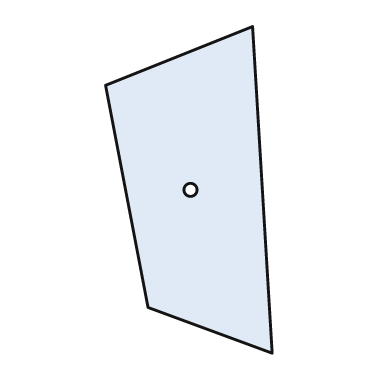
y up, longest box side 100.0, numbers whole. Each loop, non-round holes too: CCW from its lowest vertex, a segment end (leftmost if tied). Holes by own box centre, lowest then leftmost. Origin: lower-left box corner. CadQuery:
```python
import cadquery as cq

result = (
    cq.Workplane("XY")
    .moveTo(51.0, 0.0)
    .lineTo(45.0, 100.0)
    .lineTo(0.0, 82.0)
    .lineTo(13.0, 14.0)
    .close()
    .moveTo(26.0, 50.0)
    .circle(2.0)
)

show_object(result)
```